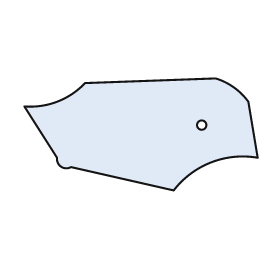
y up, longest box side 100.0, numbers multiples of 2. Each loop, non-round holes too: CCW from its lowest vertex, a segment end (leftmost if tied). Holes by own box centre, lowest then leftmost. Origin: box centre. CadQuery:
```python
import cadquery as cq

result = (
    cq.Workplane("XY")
    .moveTo(14.0, -24.0)
    .threePointArc((30.0, -12.0), (50.0, -10.0))
    .lineTo(46.0, 14.0)
    .threePointArc((40.0, 20.0), (32.0, 24.0))
    .lineTo(-24.0, 22.0)
    .threePointArc((-36.0, 14.0), (-50.0, 12.0))
    .lineTo(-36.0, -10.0)
    .threePointArc((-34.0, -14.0), (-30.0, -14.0))
    .close()
    .moveTo(26.0, 4.0)
    .circle(2.0)
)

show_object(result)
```